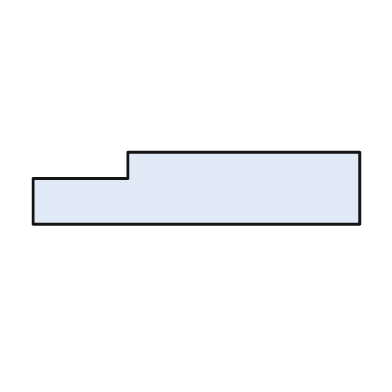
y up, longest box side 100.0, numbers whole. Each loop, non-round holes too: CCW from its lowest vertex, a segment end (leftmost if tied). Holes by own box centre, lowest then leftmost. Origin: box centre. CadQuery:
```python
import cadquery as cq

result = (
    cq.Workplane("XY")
    .moveTo(-50.0, -11.0)
    .lineTo(50.0, -11.0)
    .lineTo(50.0, 11.0)
    .lineTo(-21.0, 11.0)
    .lineTo(-21.0, 3.0)
    .lineTo(-50.0, 3.0)
    .close()
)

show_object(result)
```